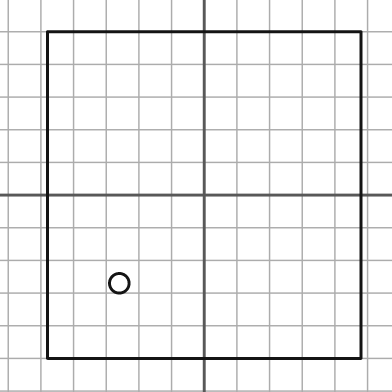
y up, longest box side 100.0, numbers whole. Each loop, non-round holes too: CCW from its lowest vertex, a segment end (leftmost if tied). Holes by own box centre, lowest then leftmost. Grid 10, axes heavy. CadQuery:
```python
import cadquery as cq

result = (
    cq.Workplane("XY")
    .moveTo(-48.0, -50.0)
    .lineTo(48.0, -50.0)
    .lineTo(48.0, 50.0)
    .lineTo(-48.0, 50.0)
    .close()
    .moveTo(-26.0, -27.0)
    .circle(3.0)
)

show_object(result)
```